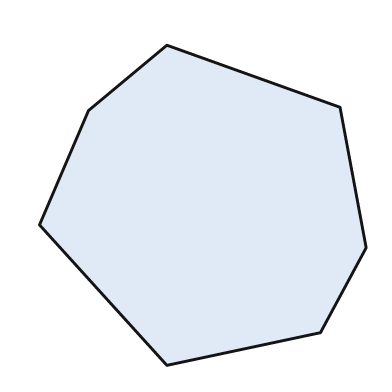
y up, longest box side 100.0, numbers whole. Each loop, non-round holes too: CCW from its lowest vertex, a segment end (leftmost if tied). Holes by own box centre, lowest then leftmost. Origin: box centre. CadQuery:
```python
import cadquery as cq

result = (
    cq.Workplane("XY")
    .moveTo(-11.0, -49.0)
    .lineTo(36.0, -39.0)
    .lineTo(50.0, -13.0)
    .lineTo(42.0, 30.0)
    .lineTo(-11.0, 49.0)
    .lineTo(-35.0, 29.0)
    .lineTo(-50.0, -6.0)
    .close()
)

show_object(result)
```